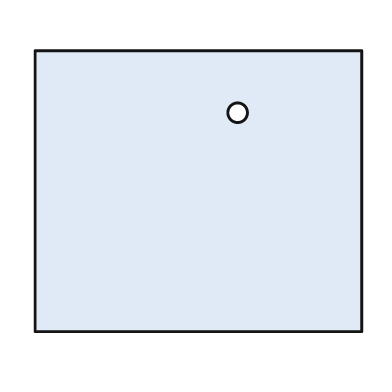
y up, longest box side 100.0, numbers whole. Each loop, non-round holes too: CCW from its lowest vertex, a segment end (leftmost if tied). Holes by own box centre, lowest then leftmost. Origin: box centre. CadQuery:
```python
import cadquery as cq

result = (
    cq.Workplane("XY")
    .moveTo(-50.0, -43.0)
    .lineTo(50.0, -43.0)
    .lineTo(50.0, 43.0)
    .lineTo(-50.0, 43.0)
    .close()
    .moveTo(12.0, 24.0)
    .circle(3.0)
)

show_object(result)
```